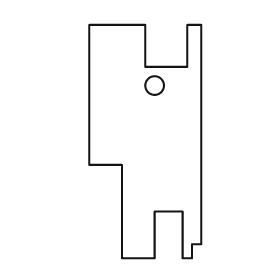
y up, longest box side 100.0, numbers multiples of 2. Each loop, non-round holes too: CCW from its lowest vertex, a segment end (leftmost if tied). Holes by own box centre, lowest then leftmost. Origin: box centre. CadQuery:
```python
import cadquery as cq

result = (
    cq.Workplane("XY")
    .moveTo(-10.0, -50.0)
    .lineTo(4.0, -50.0)
    .lineTo(4.0, -30.0)
    .lineTo(16.0, -30.0)
    .lineTo(16.0, -50.0)
    .lineTo(20.0, -50.0)
    .lineTo(20.0, -44.0)
    .lineTo(24.0, -44.0)
    .lineTo(24.0, 50.0)
    .lineTo(18.0, 50.0)
    .lineTo(18.0, 32.0)
    .lineTo(0.0, 32.0)
    .lineTo(0.0, 50.0)
    .lineTo(-24.0, 50.0)
    .lineTo(-24.0, -10.0)
    .lineTo(-10.0, -10.0)
    .close()
    .moveTo(4.0, 24.0)
    .circle(4.0)
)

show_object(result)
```